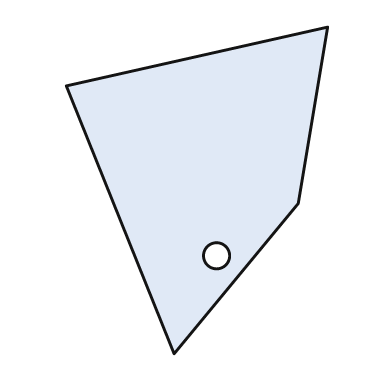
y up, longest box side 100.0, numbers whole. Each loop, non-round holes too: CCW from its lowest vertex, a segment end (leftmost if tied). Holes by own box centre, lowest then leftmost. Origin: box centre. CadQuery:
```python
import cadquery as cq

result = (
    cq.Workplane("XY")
    .moveTo(-7.0, -50.0)
    .lineTo(31.0, -4.0)
    .lineTo(40.0, 50.0)
    .lineTo(-40.0, 32.0)
    .close()
    .moveTo(6.0, -20.0)
    .circle(4.0)
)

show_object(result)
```